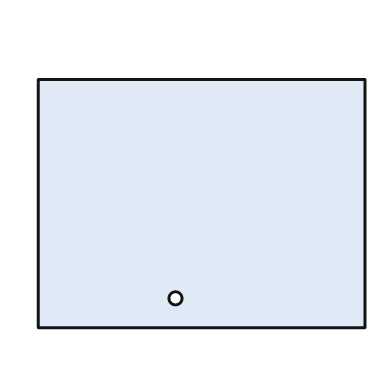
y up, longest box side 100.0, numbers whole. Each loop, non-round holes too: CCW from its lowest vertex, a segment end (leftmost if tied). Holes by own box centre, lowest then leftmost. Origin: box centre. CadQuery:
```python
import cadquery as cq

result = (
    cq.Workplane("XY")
    .moveTo(-50.0, -38.0)
    .lineTo(50.0, -38.0)
    .lineTo(50.0, 38.0)
    .lineTo(-50.0, 38.0)
    .close()
    .moveTo(-8.0, -29.0)
    .circle(2.0)
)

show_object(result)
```